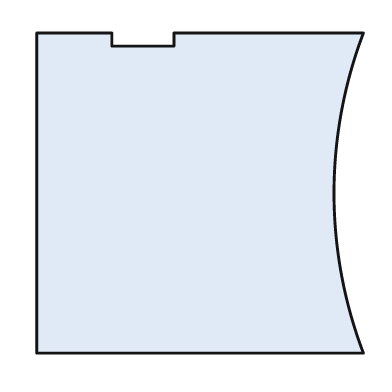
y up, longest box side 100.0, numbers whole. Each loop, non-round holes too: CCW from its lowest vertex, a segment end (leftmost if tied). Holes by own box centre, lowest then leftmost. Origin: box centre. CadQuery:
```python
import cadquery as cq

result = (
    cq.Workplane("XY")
    .moveTo(-50.0, -49.0)
    .lineTo(50.0, -49.0)
    .threePointArc((41.0, 0.0), (50.0, 49.0))
    .lineTo(-8.0, 49.0)
    .lineTo(-8.0, 45.0)
    .lineTo(-27.0, 45.0)
    .lineTo(-27.0, 49.0)
    .lineTo(-50.0, 49.0)
    .close()
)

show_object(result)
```